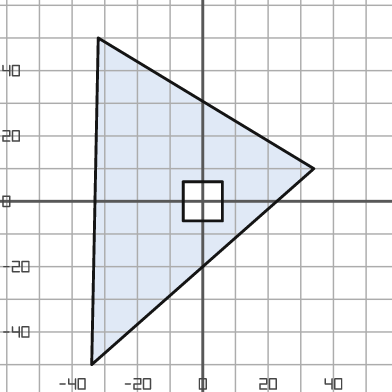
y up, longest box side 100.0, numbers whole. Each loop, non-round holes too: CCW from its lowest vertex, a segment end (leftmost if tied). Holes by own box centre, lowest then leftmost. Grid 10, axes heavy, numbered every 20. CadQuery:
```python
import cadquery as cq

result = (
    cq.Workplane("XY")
    .moveTo(-34.0, -50.0)
    .lineTo(34.0, 10.0)
    .lineTo(-32.0, 50.0)
    .close()
    .moveTo(-6.0, -6.0)
    .lineTo(6.0, -6.0)
    .lineTo(6.0, 6.0)
    .lineTo(-6.0, 6.0)
    .close()
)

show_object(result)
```